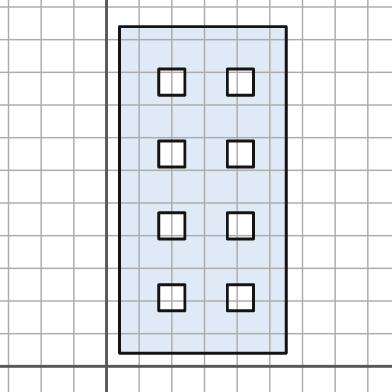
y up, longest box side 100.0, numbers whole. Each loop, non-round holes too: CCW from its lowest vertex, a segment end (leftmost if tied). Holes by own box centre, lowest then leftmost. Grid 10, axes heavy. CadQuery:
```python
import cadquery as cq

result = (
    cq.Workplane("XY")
    .moveTo(4.0, 4.0)
    .lineTo(55.0, 4.0)
    .lineTo(55.0, 104.0)
    .lineTo(4.0, 104.0)
    .close()
    .moveTo(16.0, 17.0)
    .lineTo(24.0, 17.0)
    .lineTo(24.0, 25.0)
    .lineTo(16.0, 25.0)
    .close()
    .moveTo(37.0, 17.0)
    .lineTo(45.0, 17.0)
    .lineTo(45.0, 25.0)
    .lineTo(37.0, 25.0)
    .close()
    .moveTo(16.0, 39.0)
    .lineTo(24.0, 39.0)
    .lineTo(24.0, 47.0)
    .lineTo(16.0, 47.0)
    .close()
    .moveTo(37.0, 39.0)
    .lineTo(45.0, 39.0)
    .lineTo(45.0, 47.0)
    .lineTo(37.0, 47.0)
    .close()
    .moveTo(16.0, 61.0)
    .lineTo(24.0, 61.0)
    .lineTo(24.0, 69.0)
    .lineTo(16.0, 69.0)
    .close()
    .moveTo(37.0, 61.0)
    .lineTo(45.0, 61.0)
    .lineTo(45.0, 69.0)
    .lineTo(37.0, 69.0)
    .close()
    .moveTo(16.0, 83.0)
    .lineTo(24.0, 83.0)
    .lineTo(24.0, 91.0)
    .lineTo(16.0, 91.0)
    .close()
    .moveTo(37.0, 83.0)
    .lineTo(45.0, 83.0)
    .lineTo(45.0, 91.0)
    .lineTo(37.0, 91.0)
    .close()
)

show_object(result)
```